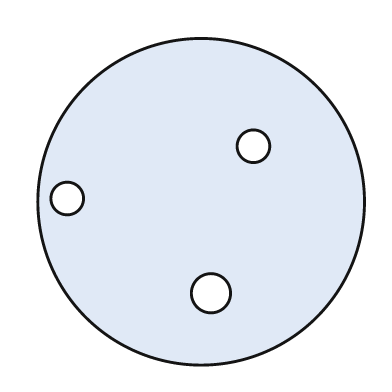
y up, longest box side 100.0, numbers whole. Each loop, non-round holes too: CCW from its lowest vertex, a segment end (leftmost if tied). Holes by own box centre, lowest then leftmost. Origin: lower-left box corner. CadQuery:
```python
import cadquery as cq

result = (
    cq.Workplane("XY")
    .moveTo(50.0, 50.0)
    .circle(50.0)
    .moveTo(53.0, 22.0)
    .circle(6.0)
    .moveTo(9.0, 51.0)
    .circle(5.0)
    .moveTo(66.0, 67.0)
    .circle(5.0)
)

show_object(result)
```